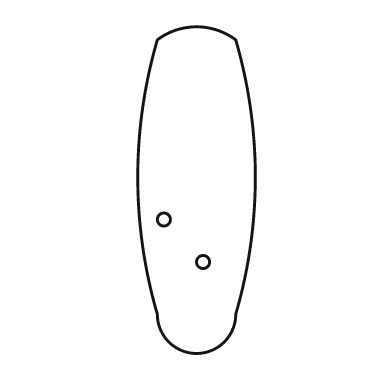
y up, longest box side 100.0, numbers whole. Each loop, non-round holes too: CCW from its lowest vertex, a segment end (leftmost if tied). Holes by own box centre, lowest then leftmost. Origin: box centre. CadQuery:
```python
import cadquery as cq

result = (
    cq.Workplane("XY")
    .moveTo(-12.0, -38.0)
    .threePointArc((0.0, -50.0), (12.0, -38.0))
    .threePointArc((18.0, 4.0), (12.0, 46.0))
    .threePointArc((0.0, 50.0), (-12.0, 46.0))
    .threePointArc((-18.0, 4.0), (-12.0, -38.0))
    .close()
    .moveTo(2.0, -22.0)
    .circle(2.0)
    .moveTo(-10.0, -9.0)
    .circle(2.0)
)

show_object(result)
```